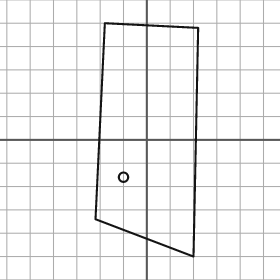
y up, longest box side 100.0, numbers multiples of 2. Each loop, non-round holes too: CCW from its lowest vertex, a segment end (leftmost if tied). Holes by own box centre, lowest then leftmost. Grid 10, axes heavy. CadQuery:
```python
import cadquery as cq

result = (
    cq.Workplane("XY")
    .moveTo(20.0, -50.0)
    .lineTo(22.0, 48.0)
    .lineTo(-18.0, 50.0)
    .lineTo(-22.0, -34.0)
    .close()
    .moveTo(-10.0, -16.0)
    .circle(2.0)
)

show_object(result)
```